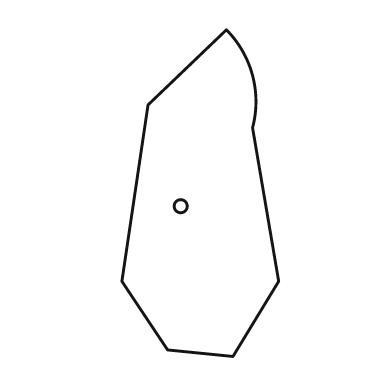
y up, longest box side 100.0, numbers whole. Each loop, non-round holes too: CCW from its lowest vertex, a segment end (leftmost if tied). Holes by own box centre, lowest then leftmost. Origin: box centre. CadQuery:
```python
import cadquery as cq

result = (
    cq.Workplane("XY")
    .moveTo(10.0, -50.0)
    .lineTo(24.0, -27.0)
    .lineTo(16.0, 20.0)
    .threePointArc((16.0, 36.0), (8.0, 50.0))
    .lineTo(-16.0, 27.0)
    .lineTo(-24.0, -27.0)
    .lineTo(-10.0, -48.0)
    .close()
    .moveTo(-6.0, -4.0)
    .circle(2.0)
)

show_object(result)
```